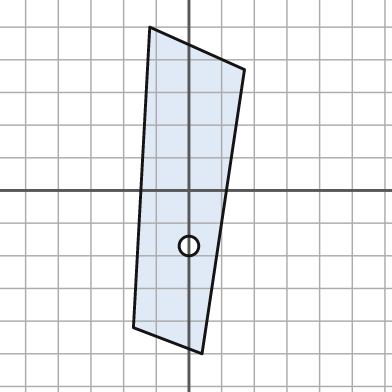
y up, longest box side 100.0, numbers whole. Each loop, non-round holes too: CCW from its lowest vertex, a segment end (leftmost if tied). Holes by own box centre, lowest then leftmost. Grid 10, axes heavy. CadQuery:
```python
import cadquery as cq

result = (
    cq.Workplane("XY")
    .moveTo(4.0, -50.0)
    .lineTo(17.0, 37.0)
    .lineTo(-12.0, 50.0)
    .lineTo(-17.0, -42.0)
    .close()
    .moveTo(0.0, -17.0)
    .circle(3.0)
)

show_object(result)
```